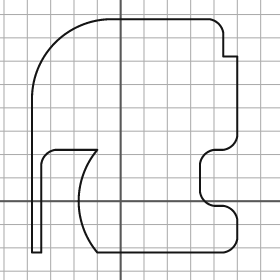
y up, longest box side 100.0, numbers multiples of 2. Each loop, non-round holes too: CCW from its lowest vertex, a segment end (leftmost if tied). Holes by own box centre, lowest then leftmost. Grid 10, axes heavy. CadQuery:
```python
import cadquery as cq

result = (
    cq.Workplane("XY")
    .moveTo(-38.0, -22.0)
    .lineTo(-34.0, -22.0)
    .lineTo(-34.0, 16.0)
    .threePointArc((-32.0, 20.0), (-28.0, 22.0))
    .lineTo(-10.0, 22.0)
    .threePointArc((-18.0, 0.0), (-10.0, -22.0))
    .lineTo(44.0, -22.0)
    .threePointArc((48.0, -20.0), (50.0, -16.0))
    .lineTo(50.0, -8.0)
    .threePointArc((48.0, -4.0), (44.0, -2.0))
    .lineTo(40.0, -2.0)
    .threePointArc((36.0, 0.0), (34.0, 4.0))
    .lineTo(34.0, 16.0)
    .threePointArc((36.0, 20.0), (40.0, 22.0))
    .lineTo(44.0, 22.0)
    .threePointArc((48.0, 24.0), (50.0, 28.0))
    .lineTo(50.0, 62.0)
    .lineTo(44.0, 62.0)
    .lineTo(44.0, 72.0)
    .threePointArc((42.0, 76.0), (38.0, 78.0))
    .lineTo(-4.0, 78.0)
    .threePointArc((-28.0, 68.0), (-38.0, 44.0))
    .close()
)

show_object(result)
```